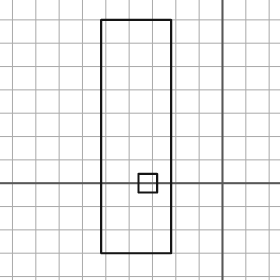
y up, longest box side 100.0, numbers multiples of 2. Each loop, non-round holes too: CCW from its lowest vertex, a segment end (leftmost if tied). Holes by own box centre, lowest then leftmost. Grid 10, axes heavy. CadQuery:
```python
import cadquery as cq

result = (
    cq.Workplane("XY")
    .moveTo(-52.0, -30.0)
    .lineTo(-22.0, -30.0)
    .lineTo(-22.0, 70.0)
    .lineTo(-52.0, 70.0)
    .close()
    .moveTo(-36.0, -4.0)
    .lineTo(-28.0, -4.0)
    .lineTo(-28.0, 4.0)
    .lineTo(-36.0, 4.0)
    .close()
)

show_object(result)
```